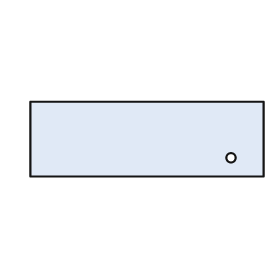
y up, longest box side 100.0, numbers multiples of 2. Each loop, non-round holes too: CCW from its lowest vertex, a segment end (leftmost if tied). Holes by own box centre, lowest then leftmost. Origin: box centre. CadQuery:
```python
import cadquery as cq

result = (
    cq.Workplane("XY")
    .moveTo(-50.0, -16.0)
    .lineTo(50.0, -16.0)
    .lineTo(50.0, 16.0)
    .lineTo(-50.0, 16.0)
    .close()
    .moveTo(36.0, -8.0)
    .circle(2.0)
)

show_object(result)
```